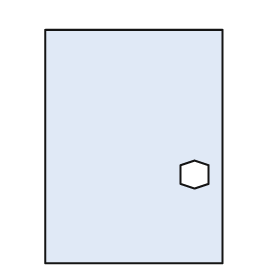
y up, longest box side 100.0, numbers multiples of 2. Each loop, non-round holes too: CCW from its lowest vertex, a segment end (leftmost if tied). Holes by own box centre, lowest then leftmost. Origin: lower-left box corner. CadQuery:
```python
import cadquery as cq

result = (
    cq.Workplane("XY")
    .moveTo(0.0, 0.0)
    .lineTo(76.0, 0.0)
    .lineTo(76.0, 100.0)
    .lineTo(0.0, 100.0)
    .close()
    .moveTo(64.0, 32.0)
    .lineTo(70.0, 34.0)
    .lineTo(70.0, 42.0)
    .lineTo(64.0, 44.0)
    .lineTo(58.0, 42.0)
    .lineTo(58.0, 34.0)
    .close()
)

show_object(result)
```